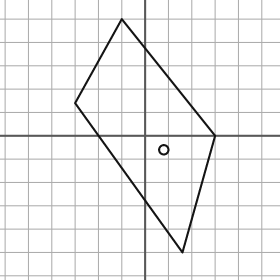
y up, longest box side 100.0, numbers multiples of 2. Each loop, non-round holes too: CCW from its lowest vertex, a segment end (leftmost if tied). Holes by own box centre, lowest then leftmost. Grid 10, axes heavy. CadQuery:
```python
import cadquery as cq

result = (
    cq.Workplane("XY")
    .moveTo(16.0, -50.0)
    .lineTo(30.0, 0.0)
    .lineTo(-10.0, 50.0)
    .lineTo(-30.0, 14.0)
    .close()
    .moveTo(8.0, -6.0)
    .circle(2.0)
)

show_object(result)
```